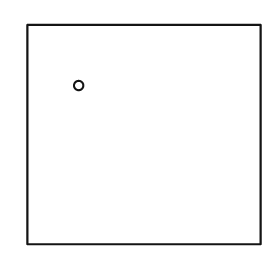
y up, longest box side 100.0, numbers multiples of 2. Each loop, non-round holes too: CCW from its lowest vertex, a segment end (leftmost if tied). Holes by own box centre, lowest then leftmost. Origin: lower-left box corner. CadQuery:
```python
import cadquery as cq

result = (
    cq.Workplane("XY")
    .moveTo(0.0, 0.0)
    .lineTo(100.0, 0.0)
    .lineTo(100.0, 94.0)
    .lineTo(0.0, 94.0)
    .close()
    .moveTo(22.0, 68.0)
    .circle(2.0)
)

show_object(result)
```